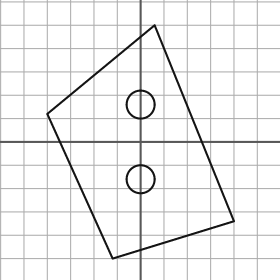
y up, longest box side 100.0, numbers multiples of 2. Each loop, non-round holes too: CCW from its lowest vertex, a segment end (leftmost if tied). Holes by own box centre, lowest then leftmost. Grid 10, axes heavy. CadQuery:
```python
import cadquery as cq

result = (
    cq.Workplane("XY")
    .moveTo(-12.0, -50.0)
    .lineTo(40.0, -34.0)
    .lineTo(6.0, 50.0)
    .lineTo(-40.0, 12.0)
    .close()
    .moveTo(0.0, -16.0)
    .circle(6.0)
    .moveTo(0.0, 16.0)
    .circle(6.0)
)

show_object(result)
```